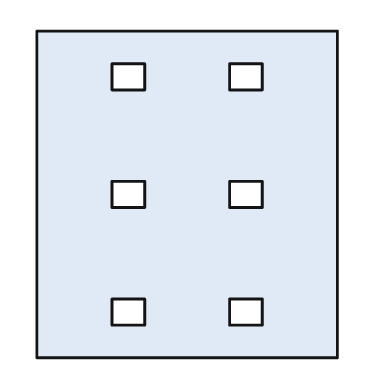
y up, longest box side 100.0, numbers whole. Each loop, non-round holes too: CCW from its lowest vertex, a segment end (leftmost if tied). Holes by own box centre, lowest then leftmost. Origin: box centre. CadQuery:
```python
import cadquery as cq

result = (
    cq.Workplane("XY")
    .moveTo(-46.0, -50.0)
    .lineTo(46.0, -50.0)
    .lineTo(46.0, 50.0)
    .lineTo(-46.0, 50.0)
    .close()
    .moveTo(-23.0, -40.0)
    .lineTo(-13.0, -40.0)
    .lineTo(-13.0, -32.0)
    .lineTo(-23.0, -32.0)
    .close()
    .moveTo(13.0, -40.0)
    .lineTo(23.0, -40.0)
    .lineTo(23.0, -32.0)
    .lineTo(13.0, -32.0)
    .close()
    .moveTo(-23.0, -4.0)
    .lineTo(-13.0, -4.0)
    .lineTo(-13.0, 4.0)
    .lineTo(-23.0, 4.0)
    .close()
    .moveTo(13.0, -4.0)
    .lineTo(23.0, -4.0)
    .lineTo(23.0, 4.0)
    .lineTo(13.0, 4.0)
    .close()
    .moveTo(-23.0, 32.0)
    .lineTo(-13.0, 32.0)
    .lineTo(-13.0, 40.0)
    .lineTo(-23.0, 40.0)
    .close()
    .moveTo(13.0, 32.0)
    .lineTo(23.0, 32.0)
    .lineTo(23.0, 40.0)
    .lineTo(13.0, 40.0)
    .close()
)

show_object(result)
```